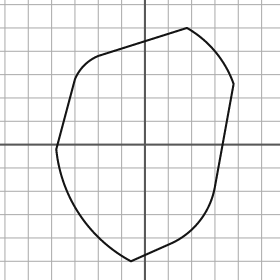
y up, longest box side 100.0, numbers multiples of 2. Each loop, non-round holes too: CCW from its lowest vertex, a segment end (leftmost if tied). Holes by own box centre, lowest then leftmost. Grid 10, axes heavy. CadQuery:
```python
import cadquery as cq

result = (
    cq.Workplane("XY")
    .moveTo(-6.0, -50.0)
    .lineTo(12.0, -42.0)
    .threePointArc((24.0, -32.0), (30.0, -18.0))
    .lineTo(38.0, 26.0)
    .threePointArc((30.0, 40.0), (18.0, 50.0))
    .lineTo(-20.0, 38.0)
    .threePointArc((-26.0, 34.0), (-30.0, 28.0))
    .lineTo(-38.0, -2.0)
    .threePointArc((-28.0, -30.0), (-6.0, -50.0))
    .close()
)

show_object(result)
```